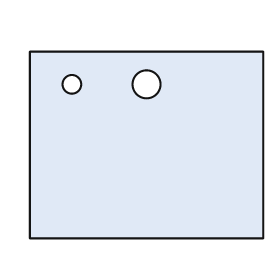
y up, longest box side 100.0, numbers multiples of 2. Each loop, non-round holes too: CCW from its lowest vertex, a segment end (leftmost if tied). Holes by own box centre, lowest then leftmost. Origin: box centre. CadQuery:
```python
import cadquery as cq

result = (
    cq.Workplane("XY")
    .moveTo(-50.0, -40.0)
    .lineTo(50.0, -40.0)
    .lineTo(50.0, 40.0)
    .lineTo(-50.0, 40.0)
    .close()
    .moveTo(-32.0, 26.0)
    .circle(4.0)
    .moveTo(0.0, 26.0)
    .circle(6.0)
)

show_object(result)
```